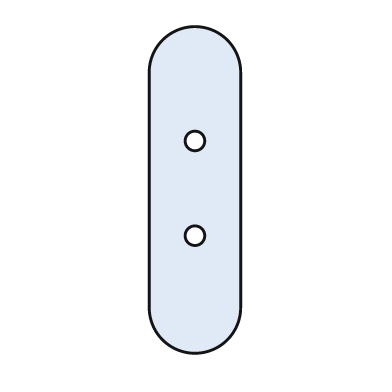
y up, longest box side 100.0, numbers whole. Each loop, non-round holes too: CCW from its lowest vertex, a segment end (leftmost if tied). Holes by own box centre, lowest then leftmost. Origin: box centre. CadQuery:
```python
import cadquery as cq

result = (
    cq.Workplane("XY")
    .moveTo(-14.0, -36.0)
    .threePointArc((0.0, -50.0), (14.0, -36.0))
    .lineTo(14.0, 36.0)
    .threePointArc((0.0, 50.0), (-14.0, 36.0))
    .close()
    .moveTo(0.0, -14.0)
    .circle(3.0)
    .moveTo(0.0, 15.0)
    .circle(3.0)
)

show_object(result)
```